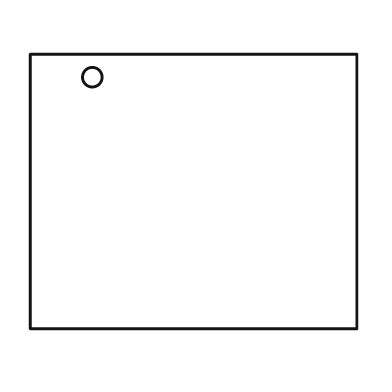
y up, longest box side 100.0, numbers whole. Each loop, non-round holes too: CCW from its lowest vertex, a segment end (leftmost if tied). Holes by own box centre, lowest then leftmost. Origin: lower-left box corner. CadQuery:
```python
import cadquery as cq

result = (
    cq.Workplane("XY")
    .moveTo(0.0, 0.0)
    .lineTo(100.0, 0.0)
    .lineTo(100.0, 84.0)
    .lineTo(0.0, 84.0)
    .close()
    .moveTo(19.0, 77.0)
    .circle(3.0)
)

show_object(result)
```